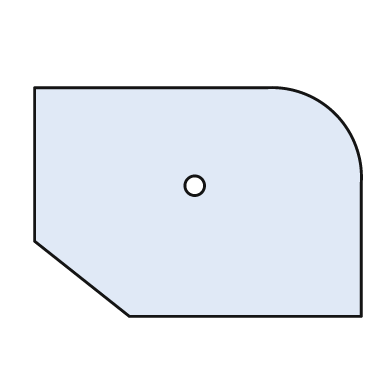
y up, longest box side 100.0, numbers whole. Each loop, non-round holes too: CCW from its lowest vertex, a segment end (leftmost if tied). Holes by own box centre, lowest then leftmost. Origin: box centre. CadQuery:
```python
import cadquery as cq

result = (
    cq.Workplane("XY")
    .moveTo(-21.0, -35.0)
    .lineTo(50.0, -35.0)
    .lineTo(50.0, 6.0)
    .threePointArc((42.0, 27.0), (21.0, 35.0))
    .lineTo(-50.0, 35.0)
    .lineTo(-50.0, -12.0)
    .close()
    .moveTo(-1.0, 5.0)
    .circle(3.0)
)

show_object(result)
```